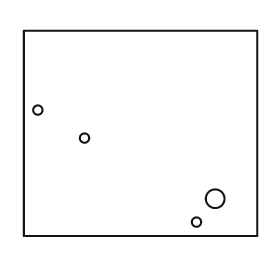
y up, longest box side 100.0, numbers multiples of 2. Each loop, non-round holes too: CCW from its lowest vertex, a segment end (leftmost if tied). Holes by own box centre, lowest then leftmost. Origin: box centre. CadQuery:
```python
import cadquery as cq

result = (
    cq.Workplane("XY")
    .moveTo(-50.0, -44.0)
    .lineTo(50.0, -44.0)
    .lineTo(50.0, 44.0)
    .lineTo(-50.0, 44.0)
    .close()
    .moveTo(24.0, -38.0)
    .circle(2.0)
    .moveTo(32.0, -28.0)
    .circle(4.0)
    .moveTo(-24.0, -2.0)
    .circle(2.0)
    .moveTo(-44.0, 10.0)
    .circle(2.0)
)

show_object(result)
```